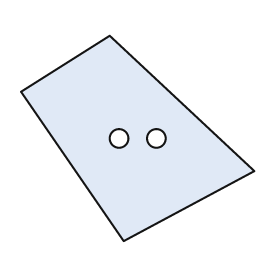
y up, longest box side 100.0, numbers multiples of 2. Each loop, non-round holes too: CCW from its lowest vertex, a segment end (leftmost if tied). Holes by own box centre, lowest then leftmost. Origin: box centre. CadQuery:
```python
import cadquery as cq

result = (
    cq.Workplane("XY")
    .moveTo(-6.0, -44.0)
    .lineTo(50.0, -14.0)
    .lineTo(-12.0, 44.0)
    .lineTo(-50.0, 20.0)
    .close()
    .moveTo(-8.0, 0.0)
    .circle(4.0)
    .moveTo(8.0, 0.0)
    .circle(4.0)
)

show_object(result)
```